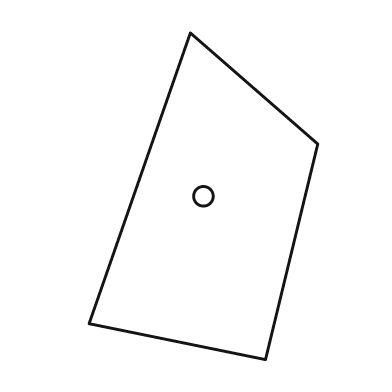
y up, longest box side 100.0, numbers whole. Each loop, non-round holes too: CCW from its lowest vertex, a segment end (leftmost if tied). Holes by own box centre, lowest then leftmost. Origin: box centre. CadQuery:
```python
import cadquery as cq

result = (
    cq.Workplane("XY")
    .moveTo(19.0, -50.0)
    .lineTo(35.0, 16.0)
    .lineTo(-4.0, 50.0)
    .lineTo(-35.0, -39.0)
    .close()
    .moveTo(0.0, 0.0)
    .circle(3.0)
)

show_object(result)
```